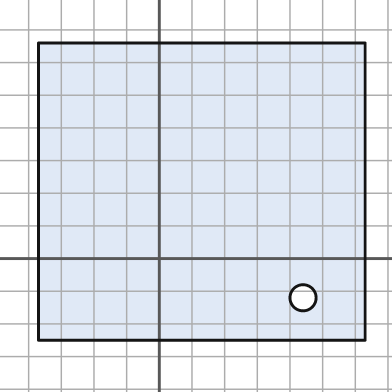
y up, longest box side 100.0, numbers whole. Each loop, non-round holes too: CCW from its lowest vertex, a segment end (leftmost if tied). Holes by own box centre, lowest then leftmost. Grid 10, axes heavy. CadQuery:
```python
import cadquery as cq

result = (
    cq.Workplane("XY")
    .moveTo(-37.0, -25.0)
    .lineTo(63.0, -25.0)
    .lineTo(63.0, 66.0)
    .lineTo(-37.0, 66.0)
    .close()
    .moveTo(44.0, -12.0)
    .circle(4.0)
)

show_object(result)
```